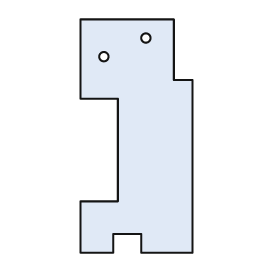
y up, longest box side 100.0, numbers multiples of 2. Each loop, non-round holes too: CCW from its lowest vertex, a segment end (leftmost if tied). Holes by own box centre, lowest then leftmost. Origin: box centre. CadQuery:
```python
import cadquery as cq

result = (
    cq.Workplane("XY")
    .moveTo(-24.0, -50.0)
    .lineTo(-10.0, -50.0)
    .lineTo(-10.0, -42.0)
    .lineTo(2.0, -42.0)
    .lineTo(2.0, -50.0)
    .lineTo(24.0, -50.0)
    .lineTo(24.0, 24.0)
    .lineTo(16.0, 24.0)
    .lineTo(16.0, 50.0)
    .lineTo(-24.0, 50.0)
    .lineTo(-24.0, 16.0)
    .lineTo(-8.0, 16.0)
    .lineTo(-8.0, -28.0)
    .lineTo(-24.0, -28.0)
    .close()
    .moveTo(-14.0, 34.0)
    .circle(2.0)
    .moveTo(4.0, 42.0)
    .circle(2.0)
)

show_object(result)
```